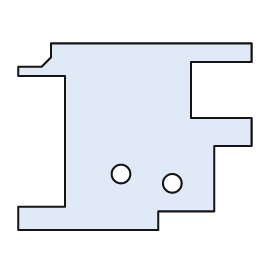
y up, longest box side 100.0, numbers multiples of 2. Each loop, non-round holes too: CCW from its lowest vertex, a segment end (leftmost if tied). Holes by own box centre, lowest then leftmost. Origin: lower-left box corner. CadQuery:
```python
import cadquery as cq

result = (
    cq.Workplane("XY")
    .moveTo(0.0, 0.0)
    .lineTo(60.0, 0.0)
    .lineTo(60.0, 8.0)
    .lineTo(84.0, 8.0)
    .lineTo(84.0, 36.0)
    .lineTo(100.0, 36.0)
    .lineTo(100.0, 48.0)
    .lineTo(74.0, 48.0)
    .lineTo(74.0, 72.0)
    .lineTo(100.0, 72.0)
    .lineTo(100.0, 80.0)
    .lineTo(14.0, 80.0)
    .lineTo(14.0, 74.0)
    .lineTo(10.0, 70.0)
    .lineTo(0.0, 70.0)
    .lineTo(0.0, 66.0)
    .lineTo(20.0, 66.0)
    .lineTo(20.0, 10.0)
    .lineTo(0.0, 10.0)
    .close()
    .moveTo(66.0, 20.0)
    .circle(4.0)
    .moveTo(44.0, 24.0)
    .circle(4.0)
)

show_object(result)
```